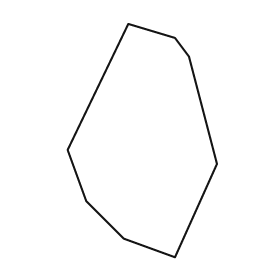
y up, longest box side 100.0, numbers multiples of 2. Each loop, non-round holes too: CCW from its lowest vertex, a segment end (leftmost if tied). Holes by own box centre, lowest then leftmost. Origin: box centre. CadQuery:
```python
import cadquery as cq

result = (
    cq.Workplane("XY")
    .moveTo(14.0, -50.0)
    .lineTo(32.0, -10.0)
    .lineTo(20.0, 36.0)
    .lineTo(14.0, 44.0)
    .lineTo(-6.0, 50.0)
    .lineTo(-32.0, -4.0)
    .lineTo(-24.0, -26.0)
    .lineTo(-8.0, -42.0)
    .close()
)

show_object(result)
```